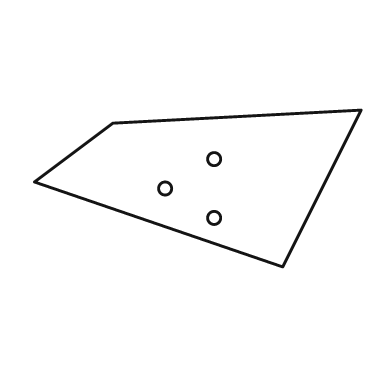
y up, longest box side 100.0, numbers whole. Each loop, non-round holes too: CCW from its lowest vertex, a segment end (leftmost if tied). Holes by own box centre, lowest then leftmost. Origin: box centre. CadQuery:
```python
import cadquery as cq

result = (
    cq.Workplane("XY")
    .moveTo(26.0, -24.0)
    .lineTo(50.0, 24.0)
    .lineTo(-26.0, 20.0)
    .lineTo(-50.0, 2.0)
    .close()
    .moveTo(5.0, -9.0)
    .circle(2.0)
    .moveTo(-10.0, 0.0)
    .circle(2.0)
    .moveTo(5.0, 9.0)
    .circle(2.0)
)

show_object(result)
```